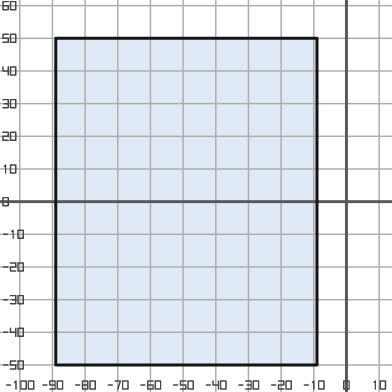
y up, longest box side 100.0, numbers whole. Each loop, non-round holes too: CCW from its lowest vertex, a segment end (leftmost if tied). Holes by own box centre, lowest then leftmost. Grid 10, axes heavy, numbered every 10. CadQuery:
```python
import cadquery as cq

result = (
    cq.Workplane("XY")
    .moveTo(-89.0, -50.0)
    .lineTo(-9.0, -50.0)
    .lineTo(-9.0, 50.0)
    .lineTo(-89.0, 50.0)
    .close()
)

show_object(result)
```